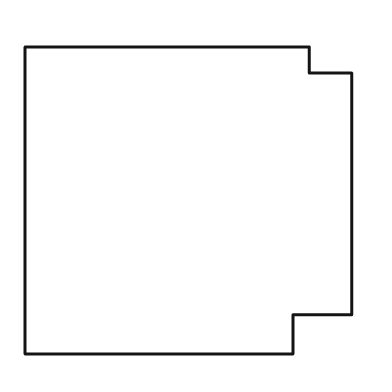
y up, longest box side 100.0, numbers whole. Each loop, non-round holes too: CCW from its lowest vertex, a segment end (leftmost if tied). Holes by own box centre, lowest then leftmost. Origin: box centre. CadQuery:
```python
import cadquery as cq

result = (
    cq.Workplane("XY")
    .moveTo(-50.0, -47.0)
    .lineTo(32.0, -47.0)
    .lineTo(32.0, -35.0)
    .lineTo(50.0, -35.0)
    .lineTo(50.0, 39.0)
    .lineTo(37.0, 39.0)
    .lineTo(37.0, 47.0)
    .lineTo(-50.0, 47.0)
    .close()
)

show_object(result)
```